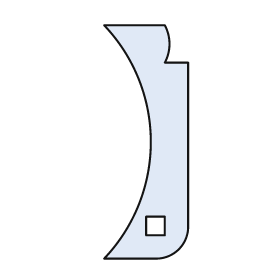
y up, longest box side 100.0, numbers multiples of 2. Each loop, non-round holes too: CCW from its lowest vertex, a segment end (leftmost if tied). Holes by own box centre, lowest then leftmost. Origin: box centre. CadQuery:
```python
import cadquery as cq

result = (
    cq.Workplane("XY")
    .moveTo(-18.0, -50.0)
    .lineTo(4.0, -50.0)
    .threePointArc((14.0, -46.0), (18.0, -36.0))
    .lineTo(18.0, 34.0)
    .lineTo(8.0, 34.0)
    .threePointArc((10.0, 42.0), (8.0, 50.0))
    .lineTo(-18.0, 50.0)
    .threePointArc((2.0, 0.0), (-18.0, -50.0))
    .close()
    .moveTo(0.0, -40.0)
    .lineTo(8.0, -40.0)
    .lineTo(8.0, -32.0)
    .lineTo(0.0, -32.0)
    .close()
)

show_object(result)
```